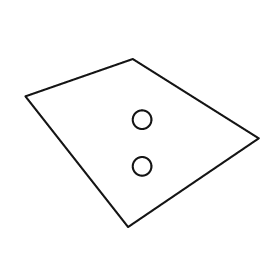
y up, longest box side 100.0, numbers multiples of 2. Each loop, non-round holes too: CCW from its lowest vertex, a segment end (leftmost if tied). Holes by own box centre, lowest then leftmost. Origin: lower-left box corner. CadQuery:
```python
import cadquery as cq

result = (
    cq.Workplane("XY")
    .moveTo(44.0, 0.0)
    .lineTo(100.0, 38.0)
    .lineTo(46.0, 72.0)
    .lineTo(0.0, 56.0)
    .close()
    .moveTo(50.0, 26.0)
    .circle(4.0)
    .moveTo(50.0, 46.0)
    .circle(4.0)
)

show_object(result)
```